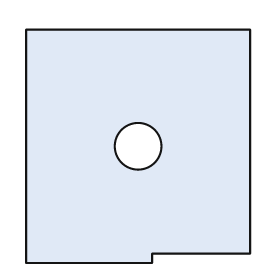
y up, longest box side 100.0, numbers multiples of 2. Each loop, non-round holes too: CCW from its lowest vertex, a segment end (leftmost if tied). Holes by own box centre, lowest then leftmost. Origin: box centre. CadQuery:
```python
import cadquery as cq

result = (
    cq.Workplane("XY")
    .moveTo(-48.0, -50.0)
    .lineTo(6.0, -50.0)
    .lineTo(6.0, -46.0)
    .lineTo(48.0, -46.0)
    .lineTo(48.0, 50.0)
    .lineTo(-48.0, 50.0)
    .close()
    .moveTo(0.0, 0.0)
    .circle(10.0)
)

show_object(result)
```